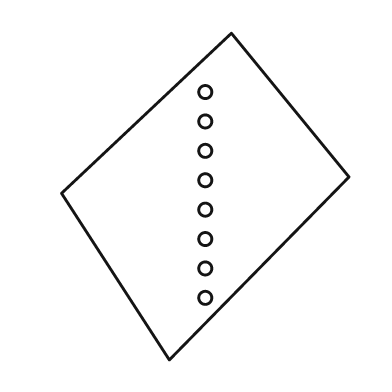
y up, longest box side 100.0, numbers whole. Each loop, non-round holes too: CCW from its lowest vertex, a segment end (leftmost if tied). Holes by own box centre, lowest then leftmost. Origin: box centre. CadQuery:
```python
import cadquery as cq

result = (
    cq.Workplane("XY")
    .moveTo(-11.0, -50.0)
    .lineTo(44.0, 6.0)
    .lineTo(8.0, 50.0)
    .lineTo(-44.0, 1.0)
    .close()
    .moveTo(0.0, -31.0)
    .circle(2.0)
    .moveTo(0.0, -22.0)
    .circle(2.0)
    .moveTo(0.0, -13.0)
    .circle(2.0)
    .moveTo(0.0, -4.0)
    .circle(2.0)
    .moveTo(0.0, 5.0)
    .circle(2.0)
    .moveTo(0.0, 14.0)
    .circle(2.0)
    .moveTo(0.0, 23.0)
    .circle(2.0)
    .moveTo(0.0, 32.0)
    .circle(2.0)
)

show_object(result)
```